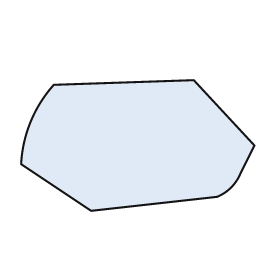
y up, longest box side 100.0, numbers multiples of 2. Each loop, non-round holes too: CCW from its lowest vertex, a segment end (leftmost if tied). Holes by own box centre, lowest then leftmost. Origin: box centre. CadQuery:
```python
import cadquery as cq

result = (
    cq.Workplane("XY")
    .moveTo(-20.0, -28.0)
    .lineTo(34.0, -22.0)
    .threePointArc((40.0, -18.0), (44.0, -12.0))
    .lineTo(50.0, 0.0)
    .lineTo(24.0, 28.0)
    .lineTo(-36.0, 26.0)
    .threePointArc((-46.0, 10.0), (-50.0, -8.0))
    .close()
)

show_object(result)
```